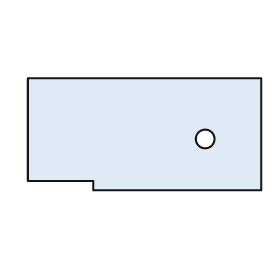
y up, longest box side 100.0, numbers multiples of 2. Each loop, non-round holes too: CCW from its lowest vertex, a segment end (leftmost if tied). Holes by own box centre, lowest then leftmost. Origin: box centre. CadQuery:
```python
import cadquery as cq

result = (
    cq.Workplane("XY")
    .moveTo(-22.0, -24.0)
    .lineTo(50.0, -24.0)
    .lineTo(50.0, 24.0)
    .lineTo(-50.0, 24.0)
    .lineTo(-50.0, -20.0)
    .lineTo(-22.0, -20.0)
    .close()
    .moveTo(26.0, -2.0)
    .circle(4.0)
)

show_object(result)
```